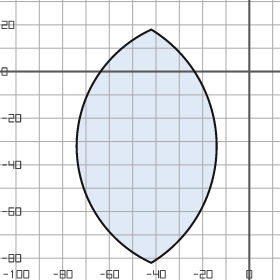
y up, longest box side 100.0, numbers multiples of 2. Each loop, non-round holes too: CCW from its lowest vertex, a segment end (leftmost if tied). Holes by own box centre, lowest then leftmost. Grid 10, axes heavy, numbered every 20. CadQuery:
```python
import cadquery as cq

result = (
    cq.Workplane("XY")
    .moveTo(-42.0, -82.0)
    .threePointArc((-14.0, -32.0), (-42.0, 18.0))
    .threePointArc((-74.0, -32.0), (-42.0, -82.0))
    .close()
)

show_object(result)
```